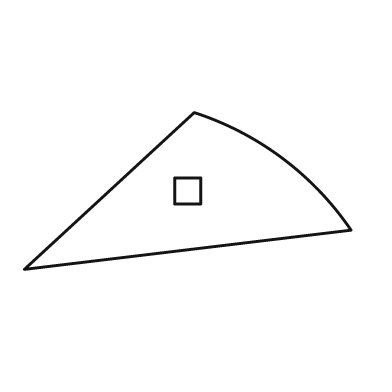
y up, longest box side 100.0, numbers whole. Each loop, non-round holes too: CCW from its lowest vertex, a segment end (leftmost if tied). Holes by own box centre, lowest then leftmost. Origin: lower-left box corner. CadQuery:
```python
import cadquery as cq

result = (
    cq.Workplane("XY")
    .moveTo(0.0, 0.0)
    .lineTo(100.0, 12.0)
    .threePointArc((79.0, 34.0), (52.0, 48.0))
    .close()
    .moveTo(46.0, 20.0)
    .lineTo(54.0, 20.0)
    .lineTo(54.0, 28.0)
    .lineTo(46.0, 28.0)
    .close()
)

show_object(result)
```